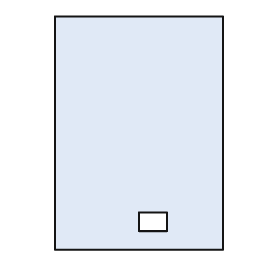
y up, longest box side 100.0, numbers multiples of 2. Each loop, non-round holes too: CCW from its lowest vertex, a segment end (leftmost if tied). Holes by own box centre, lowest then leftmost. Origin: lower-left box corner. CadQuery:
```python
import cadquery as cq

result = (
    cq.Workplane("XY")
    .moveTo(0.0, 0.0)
    .lineTo(72.0, 0.0)
    .lineTo(72.0, 100.0)
    .lineTo(0.0, 100.0)
    .close()
    .moveTo(36.0, 8.0)
    .lineTo(48.0, 8.0)
    .lineTo(48.0, 16.0)
    .lineTo(36.0, 16.0)
    .close()
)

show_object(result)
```